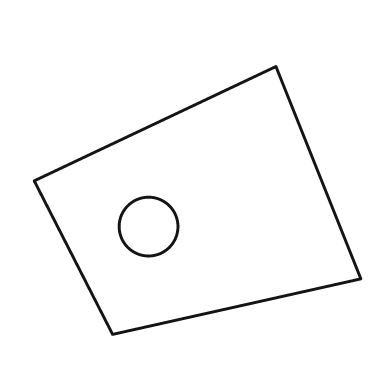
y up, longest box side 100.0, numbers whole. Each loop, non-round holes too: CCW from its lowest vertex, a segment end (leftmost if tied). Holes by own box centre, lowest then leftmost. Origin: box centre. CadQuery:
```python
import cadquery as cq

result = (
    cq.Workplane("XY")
    .moveTo(-26.0, -41.0)
    .lineTo(50.0, -24.0)
    .lineTo(24.0, 41.0)
    .lineTo(-50.0, 6.0)
    .close()
    .moveTo(-15.0, -8.0)
    .circle(9.0)
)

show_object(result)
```